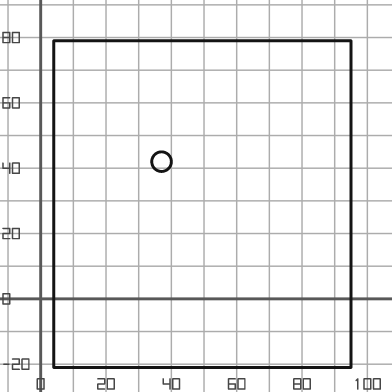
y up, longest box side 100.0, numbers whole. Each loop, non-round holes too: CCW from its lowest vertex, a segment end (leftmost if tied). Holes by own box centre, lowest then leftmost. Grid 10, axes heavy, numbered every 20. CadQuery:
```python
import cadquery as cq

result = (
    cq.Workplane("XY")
    .moveTo(4.0, -21.0)
    .lineTo(95.0, -21.0)
    .lineTo(95.0, 79.0)
    .lineTo(4.0, 79.0)
    .close()
    .moveTo(37.0, 42.0)
    .circle(3.0)
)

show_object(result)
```